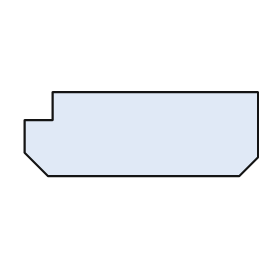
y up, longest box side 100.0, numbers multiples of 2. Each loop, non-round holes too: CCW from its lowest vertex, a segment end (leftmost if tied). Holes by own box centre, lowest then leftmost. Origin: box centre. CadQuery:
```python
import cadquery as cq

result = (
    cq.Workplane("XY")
    .moveTo(-40.0, -18.0)
    .lineTo(42.0, -18.0)
    .lineTo(50.0, -10.0)
    .lineTo(50.0, 18.0)
    .lineTo(-38.0, 18.0)
    .lineTo(-38.0, 6.0)
    .lineTo(-50.0, 6.0)
    .lineTo(-50.0, -8.0)
    .close()
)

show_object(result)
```